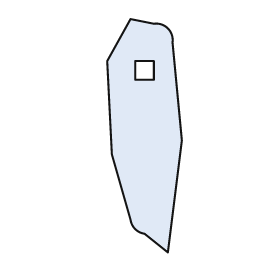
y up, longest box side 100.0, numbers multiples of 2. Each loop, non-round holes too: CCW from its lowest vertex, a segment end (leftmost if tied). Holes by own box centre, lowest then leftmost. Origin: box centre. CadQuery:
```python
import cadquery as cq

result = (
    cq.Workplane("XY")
    .moveTo(10.0, -50.0)
    .lineTo(16.0, -2.0)
    .lineTo(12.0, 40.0)
    .threePointArc((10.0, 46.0), (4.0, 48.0))
    .lineTo(-6.0, 50.0)
    .lineTo(-16.0, 32.0)
    .lineTo(-14.0, -8.0)
    .lineTo(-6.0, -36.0)
    .threePointArc((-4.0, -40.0), (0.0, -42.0))
    .close()
    .moveTo(-4.0, 24.0)
    .lineTo(4.0, 24.0)
    .lineTo(4.0, 32.0)
    .lineTo(-4.0, 32.0)
    .close()
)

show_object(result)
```